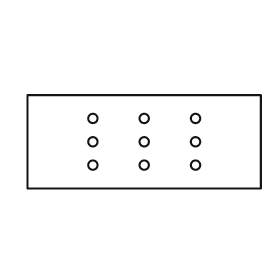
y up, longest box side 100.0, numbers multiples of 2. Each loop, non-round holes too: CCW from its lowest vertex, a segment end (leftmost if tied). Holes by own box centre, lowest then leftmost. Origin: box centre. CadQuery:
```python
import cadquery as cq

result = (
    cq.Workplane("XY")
    .moveTo(-50.0, -20.0)
    .lineTo(50.0, -20.0)
    .lineTo(50.0, 20.0)
    .lineTo(-50.0, 20.0)
    .close()
    .moveTo(-22.0, -10.0)
    .circle(2.0)
    .moveTo(0.0, -10.0)
    .circle(2.0)
    .moveTo(22.0, -10.0)
    .circle(2.0)
    .moveTo(-22.0, 0.0)
    .circle(2.0)
    .moveTo(0.0, 0.0)
    .circle(2.0)
    .moveTo(22.0, 0.0)
    .circle(2.0)
    .moveTo(-22.0, 10.0)
    .circle(2.0)
    .moveTo(0.0, 10.0)
    .circle(2.0)
    .moveTo(22.0, 10.0)
    .circle(2.0)
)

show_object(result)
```